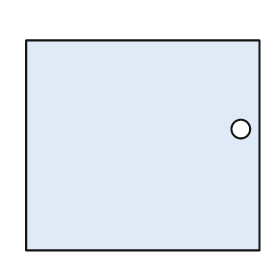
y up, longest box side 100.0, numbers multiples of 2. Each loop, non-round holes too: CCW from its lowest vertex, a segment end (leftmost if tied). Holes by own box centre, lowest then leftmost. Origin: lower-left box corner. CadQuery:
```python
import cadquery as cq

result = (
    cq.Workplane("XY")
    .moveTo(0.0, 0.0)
    .lineTo(100.0, 0.0)
    .lineTo(100.0, 90.0)
    .lineTo(0.0, 90.0)
    .close()
    .moveTo(92.0, 52.0)
    .circle(4.0)
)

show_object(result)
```